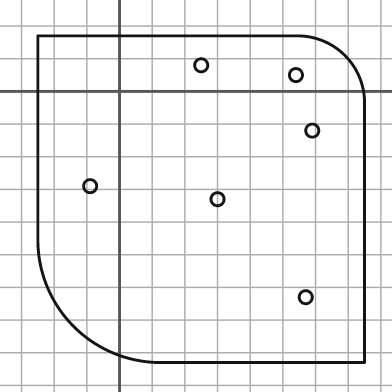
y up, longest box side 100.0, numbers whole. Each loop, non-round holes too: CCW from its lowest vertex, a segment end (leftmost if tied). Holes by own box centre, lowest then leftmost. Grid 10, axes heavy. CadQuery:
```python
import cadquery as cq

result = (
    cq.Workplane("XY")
    .moveTo(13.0, -83.0)
    .lineTo(75.0, -83.0)
    .lineTo(75.0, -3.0)
    .threePointArc((69.0, 11.0), (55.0, 17.0))
    .lineTo(-25.0, 17.0)
    .lineTo(-25.0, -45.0)
    .threePointArc((-14.0, -72.0), (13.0, -83.0))
    .close()
    .moveTo(57.0, -63.0)
    .circle(2.0)
    .moveTo(30.0, -33.0)
    .circle(2.0)
    .moveTo(-9.0, -29.0)
    .circle(2.0)
    .moveTo(59.0, -12.0)
    .circle(2.0)
    .moveTo(54.0, 5.0)
    .circle(2.0)
    .moveTo(25.0, 8.0)
    .circle(2.0)
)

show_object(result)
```